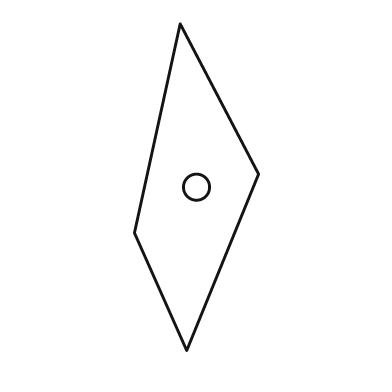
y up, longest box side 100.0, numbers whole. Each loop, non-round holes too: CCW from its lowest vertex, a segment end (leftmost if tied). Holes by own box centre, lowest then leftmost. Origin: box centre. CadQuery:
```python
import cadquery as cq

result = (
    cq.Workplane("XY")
    .moveTo(-3.0, -50.0)
    .lineTo(19.0, 4.0)
    .lineTo(-5.0, 50.0)
    .lineTo(-19.0, -14.0)
    .close()
    .moveTo(0.0, 0.0)
    .circle(4.0)
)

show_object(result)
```